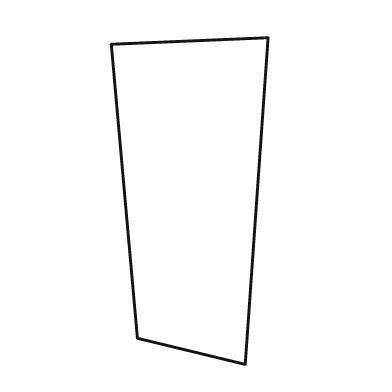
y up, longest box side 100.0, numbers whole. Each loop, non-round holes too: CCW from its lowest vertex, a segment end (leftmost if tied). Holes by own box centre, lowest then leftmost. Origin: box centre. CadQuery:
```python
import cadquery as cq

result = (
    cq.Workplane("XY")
    .moveTo(17.0, -50.0)
    .lineTo(24.0, 50.0)
    .lineTo(-24.0, 48.0)
    .lineTo(-16.0, -42.0)
    .close()
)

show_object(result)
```